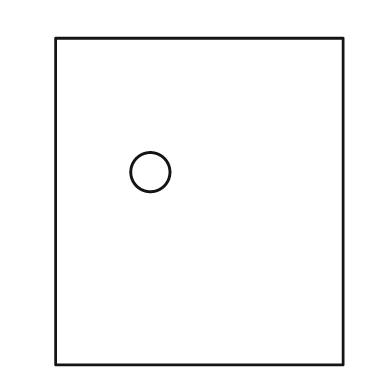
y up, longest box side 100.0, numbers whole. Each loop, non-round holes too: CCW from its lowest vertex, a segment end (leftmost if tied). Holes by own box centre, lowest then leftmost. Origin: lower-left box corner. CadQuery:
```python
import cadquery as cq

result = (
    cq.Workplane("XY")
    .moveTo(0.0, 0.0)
    .lineTo(88.0, 0.0)
    .lineTo(88.0, 100.0)
    .lineTo(0.0, 100.0)
    .close()
    .moveTo(29.0, 59.0)
    .circle(6.0)
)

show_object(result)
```